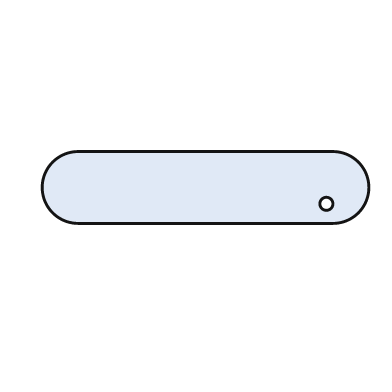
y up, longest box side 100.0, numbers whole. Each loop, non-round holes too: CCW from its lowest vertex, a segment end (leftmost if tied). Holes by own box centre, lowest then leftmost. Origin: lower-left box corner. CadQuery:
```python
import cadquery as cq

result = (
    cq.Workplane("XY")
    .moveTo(11.0, 0.0)
    .lineTo(89.0, 0.0)
    .threePointArc((100.0, 11.0), (89.0, 22.0))
    .lineTo(11.0, 22.0)
    .threePointArc((0.0, 11.0), (11.0, 0.0))
    .close()
    .moveTo(87.0, 6.0)
    .circle(2.0)
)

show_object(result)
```